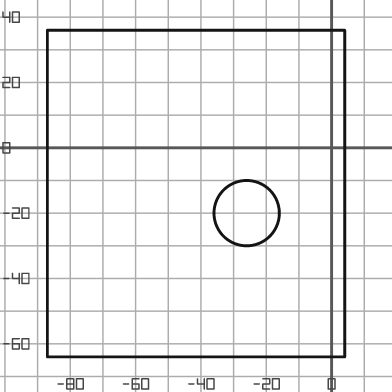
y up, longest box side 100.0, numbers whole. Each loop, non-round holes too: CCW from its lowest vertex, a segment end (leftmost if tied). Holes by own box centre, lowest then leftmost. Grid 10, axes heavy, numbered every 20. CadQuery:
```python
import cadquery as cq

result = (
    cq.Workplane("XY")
    .moveTo(-87.0, -64.0)
    .lineTo(4.0, -64.0)
    .lineTo(4.0, 36.0)
    .lineTo(-87.0, 36.0)
    .close()
    .moveTo(-26.0, -20.0)
    .circle(10.0)
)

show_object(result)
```